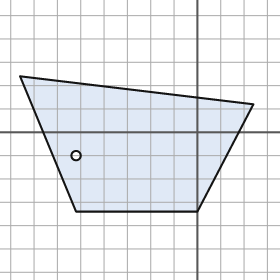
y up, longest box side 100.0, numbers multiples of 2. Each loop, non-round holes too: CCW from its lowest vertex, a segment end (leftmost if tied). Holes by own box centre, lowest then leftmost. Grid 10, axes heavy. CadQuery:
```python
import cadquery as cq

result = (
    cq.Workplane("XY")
    .moveTo(-52.0, -34.0)
    .lineTo(0.0, -34.0)
    .lineTo(24.0, 12.0)
    .lineTo(-76.0, 24.0)
    .close()
    .moveTo(-52.0, -10.0)
    .circle(2.0)
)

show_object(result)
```